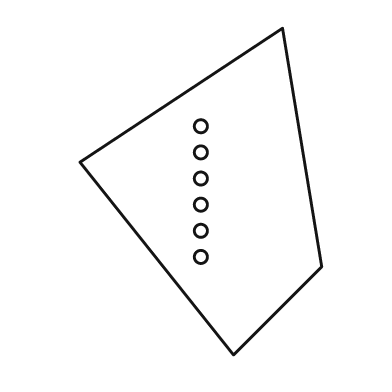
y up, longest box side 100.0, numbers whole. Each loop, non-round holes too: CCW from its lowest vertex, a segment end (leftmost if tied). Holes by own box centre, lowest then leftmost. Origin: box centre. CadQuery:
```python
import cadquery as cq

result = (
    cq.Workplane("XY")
    .moveTo(10.0, -50.0)
    .lineTo(37.0, -23.0)
    .lineTo(25.0, 50.0)
    .lineTo(-37.0, 9.0)
    .close()
    .moveTo(0.0, -20.0)
    .circle(2.0)
    .moveTo(0.0, -12.0)
    .circle(2.0)
    .moveTo(0.0, -4.0)
    .circle(2.0)
    .moveTo(0.0, 4.0)
    .circle(2.0)
    .moveTo(0.0, 12.0)
    .circle(2.0)
    .moveTo(0.0, 20.0)
    .circle(2.0)
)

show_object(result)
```